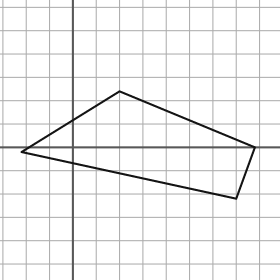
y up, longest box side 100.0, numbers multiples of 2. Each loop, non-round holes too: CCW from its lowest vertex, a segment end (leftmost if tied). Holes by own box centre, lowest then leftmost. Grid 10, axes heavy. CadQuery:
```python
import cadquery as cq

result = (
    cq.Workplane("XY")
    .moveTo(70.0, -22.0)
    .lineTo(78.0, 0.0)
    .lineTo(20.0, 24.0)
    .lineTo(-22.0, -2.0)
    .close()
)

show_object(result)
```